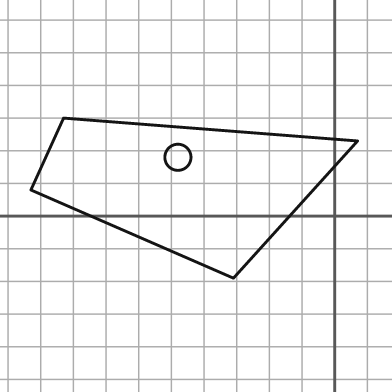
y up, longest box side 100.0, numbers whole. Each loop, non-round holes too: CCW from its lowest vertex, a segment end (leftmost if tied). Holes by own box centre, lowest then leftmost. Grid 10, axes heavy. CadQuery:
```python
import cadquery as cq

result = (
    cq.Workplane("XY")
    .moveTo(-31.0, -19.0)
    .lineTo(7.0, 23.0)
    .lineTo(-83.0, 30.0)
    .lineTo(-93.0, 8.0)
    .close()
    .moveTo(-48.0, 18.0)
    .circle(4.0)
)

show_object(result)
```